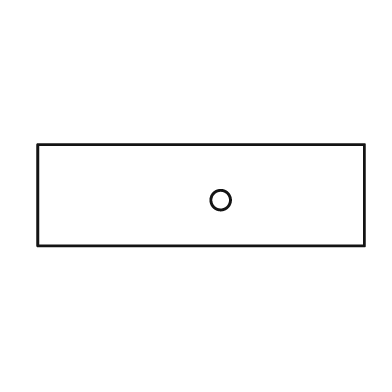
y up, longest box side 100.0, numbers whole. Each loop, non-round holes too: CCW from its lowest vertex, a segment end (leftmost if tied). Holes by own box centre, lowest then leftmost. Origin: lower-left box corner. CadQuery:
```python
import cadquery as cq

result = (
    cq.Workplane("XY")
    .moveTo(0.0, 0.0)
    .lineTo(100.0, 0.0)
    .lineTo(100.0, 31.0)
    .lineTo(0.0, 31.0)
    .close()
    .moveTo(56.0, 14.0)
    .circle(3.0)
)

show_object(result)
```